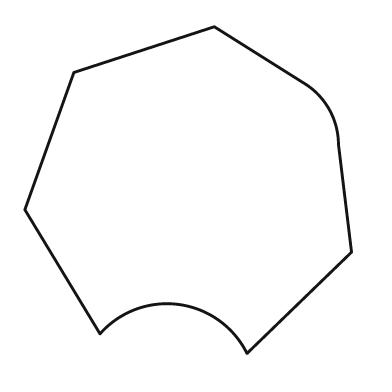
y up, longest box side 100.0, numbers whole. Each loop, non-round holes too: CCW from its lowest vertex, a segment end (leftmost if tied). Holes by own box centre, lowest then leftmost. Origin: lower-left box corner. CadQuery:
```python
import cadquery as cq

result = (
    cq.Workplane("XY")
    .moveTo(68.0, 0.0)
    .lineTo(100.0, 31.0)
    .lineTo(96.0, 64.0)
    .threePointArc((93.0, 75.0), (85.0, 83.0))
    .lineTo(58.0, 100.0)
    .lineTo(15.0, 86.0)
    .lineTo(0.0, 44.0)
    .lineTo(23.0, 6.0)
    .threePointArc((47.0, 15.0), (68.0, 0.0))
    .close()
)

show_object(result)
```